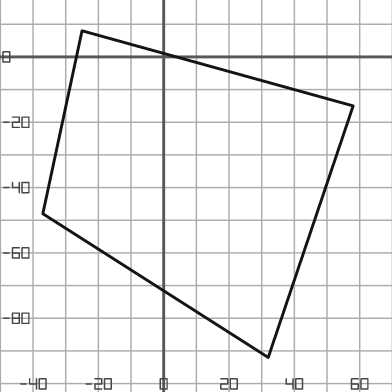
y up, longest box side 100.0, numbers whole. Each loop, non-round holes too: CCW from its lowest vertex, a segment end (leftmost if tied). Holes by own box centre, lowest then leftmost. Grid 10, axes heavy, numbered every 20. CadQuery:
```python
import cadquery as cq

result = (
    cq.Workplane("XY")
    .moveTo(32.0, -92.0)
    .lineTo(58.0, -15.0)
    .lineTo(-25.0, 8.0)
    .lineTo(-37.0, -48.0)
    .close()
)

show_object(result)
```